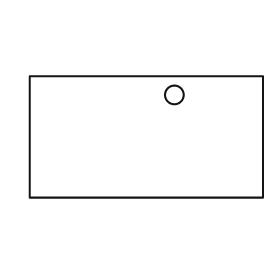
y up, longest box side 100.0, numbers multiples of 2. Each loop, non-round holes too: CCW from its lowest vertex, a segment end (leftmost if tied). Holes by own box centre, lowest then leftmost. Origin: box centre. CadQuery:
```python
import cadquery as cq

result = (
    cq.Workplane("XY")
    .moveTo(-50.0, -26.0)
    .lineTo(50.0, -26.0)
    .lineTo(50.0, 26.0)
    .lineTo(-50.0, 26.0)
    .close()
    .moveTo(12.0, 18.0)
    .circle(4.0)
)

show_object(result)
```